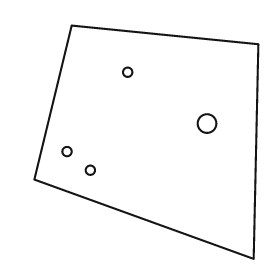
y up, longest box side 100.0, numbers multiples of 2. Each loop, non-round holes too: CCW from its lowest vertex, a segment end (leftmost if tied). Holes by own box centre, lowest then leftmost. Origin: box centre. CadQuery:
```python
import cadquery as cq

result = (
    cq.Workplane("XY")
    .moveTo(46.0, -50.0)
    .lineTo(48.0, 42.0)
    .lineTo(-32.0, 50.0)
    .lineTo(-48.0, -16.0)
    .close()
    .moveTo(-24.0, -12.0)
    .circle(2.0)
    .moveTo(-34.0, -4.0)
    .circle(2.0)
    .moveTo(26.0, 8.0)
    .circle(4.0)
    .moveTo(-8.0, 30.0)
    .circle(2.0)
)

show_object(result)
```